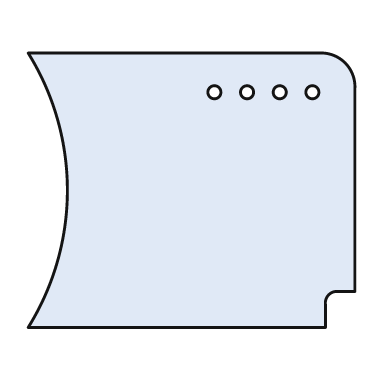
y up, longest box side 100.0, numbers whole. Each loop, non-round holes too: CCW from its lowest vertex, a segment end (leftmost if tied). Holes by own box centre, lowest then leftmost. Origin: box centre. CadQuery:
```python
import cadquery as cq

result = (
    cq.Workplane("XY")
    .moveTo(-50.0, -42.0)
    .lineTo(41.0, -42.0)
    .lineTo(41.0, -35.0)
    .threePointArc((42.0, -32.0), (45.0, -31.0))
    .lineTo(50.0, -31.0)
    .lineTo(50.0, 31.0)
    .threePointArc((47.0, 39.0), (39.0, 42.0))
    .lineTo(-50.0, 42.0)
    .threePointArc((-38.0, 0.0), (-50.0, -42.0))
    .close()
    .moveTo(7.0, 30.0)
    .circle(2.0)
    .moveTo(17.0, 30.0)
    .circle(2.0)
    .moveTo(27.0, 30.0)
    .circle(2.0)
    .moveTo(37.0, 30.0)
    .circle(2.0)
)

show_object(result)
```